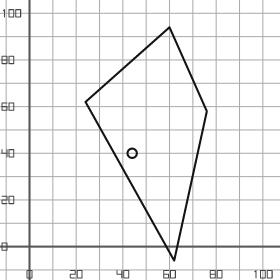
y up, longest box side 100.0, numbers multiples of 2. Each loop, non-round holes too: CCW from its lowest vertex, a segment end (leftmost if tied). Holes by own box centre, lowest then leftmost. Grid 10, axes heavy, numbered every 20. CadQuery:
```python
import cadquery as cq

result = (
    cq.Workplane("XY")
    .moveTo(62.0, -6.0)
    .lineTo(76.0, 58.0)
    .lineTo(60.0, 94.0)
    .lineTo(24.0, 62.0)
    .close()
    .moveTo(44.0, 40.0)
    .circle(2.0)
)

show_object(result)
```